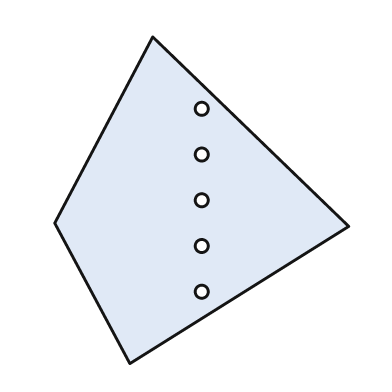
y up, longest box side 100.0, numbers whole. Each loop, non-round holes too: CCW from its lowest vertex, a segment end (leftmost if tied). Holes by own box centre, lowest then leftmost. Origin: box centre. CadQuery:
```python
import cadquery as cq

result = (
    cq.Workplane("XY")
    .moveTo(-22.0, -50.0)
    .lineTo(45.0, -8.0)
    .lineTo(-15.0, 50.0)
    .lineTo(-45.0, -7.0)
    .close()
    .moveTo(0.0, -28.0)
    .circle(2.0)
    .moveTo(0.0, -14.0)
    .circle(2.0)
    .moveTo(0.0, 0.0)
    .circle(2.0)
    .moveTo(0.0, 14.0)
    .circle(2.0)
    .moveTo(0.0, 28.0)
    .circle(2.0)
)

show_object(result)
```